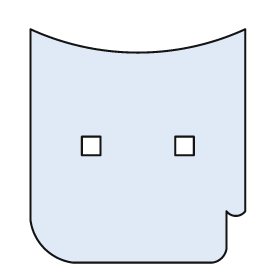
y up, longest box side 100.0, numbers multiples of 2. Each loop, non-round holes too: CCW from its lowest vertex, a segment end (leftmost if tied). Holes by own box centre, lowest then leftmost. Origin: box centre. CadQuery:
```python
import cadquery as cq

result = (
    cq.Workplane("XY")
    .moveTo(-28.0, -50.0)
    .lineTo(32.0, -50.0)
    .threePointArc((36.0, -48.0), (38.0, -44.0))
    .lineTo(38.0, -28.0)
    .threePointArc((42.0, -30.0), (46.0, -28.0))
    .lineTo(46.0, 50.0)
    .threePointArc((0.0, 40.0), (-46.0, 50.0))
    .lineTo(-46.0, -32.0)
    .threePointArc((-40.0, -44.0), (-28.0, -50.0))
    .close()
    .moveTo(-24.0, -4.0)
    .lineTo(-16.0, -4.0)
    .lineTo(-16.0, 4.0)
    .lineTo(-24.0, 4.0)
    .close()
    .moveTo(16.0, -4.0)
    .lineTo(24.0, -4.0)
    .lineTo(24.0, 4.0)
    .lineTo(16.0, 4.0)
    .close()
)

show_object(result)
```